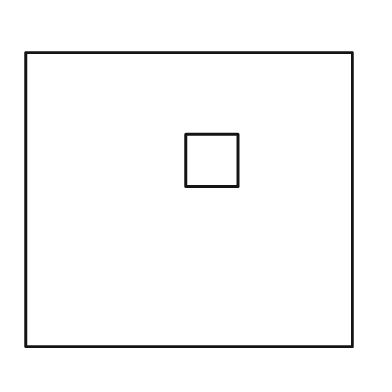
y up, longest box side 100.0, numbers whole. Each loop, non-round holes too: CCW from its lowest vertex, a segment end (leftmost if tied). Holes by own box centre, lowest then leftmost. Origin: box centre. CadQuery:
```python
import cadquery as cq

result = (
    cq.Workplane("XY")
    .moveTo(-50.0, -45.0)
    .lineTo(50.0, -45.0)
    .lineTo(50.0, 45.0)
    .lineTo(-50.0, 45.0)
    .close()
    .moveTo(-1.0, 4.0)
    .lineTo(15.0, 4.0)
    .lineTo(15.0, 20.0)
    .lineTo(-1.0, 20.0)
    .close()
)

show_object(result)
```